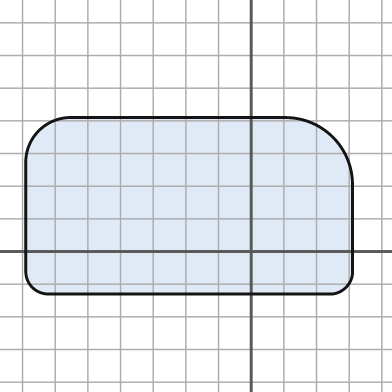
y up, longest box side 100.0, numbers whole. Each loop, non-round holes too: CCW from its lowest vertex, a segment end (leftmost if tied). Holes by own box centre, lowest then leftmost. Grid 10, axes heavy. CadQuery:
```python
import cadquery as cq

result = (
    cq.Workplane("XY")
    .moveTo(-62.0, -13.0)
    .lineTo(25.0, -13.0)
    .threePointArc((29.0, -11.0), (31.0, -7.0))
    .lineTo(31.0, 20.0)
    .threePointArc((25.0, 35.0), (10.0, 41.0))
    .lineTo(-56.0, 41.0)
    .threePointArc((-65.0, 37.0), (-69.0, 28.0))
    .lineTo(-69.0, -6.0)
    .threePointArc((-67.0, -11.0), (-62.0, -13.0))
    .close()
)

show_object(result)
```